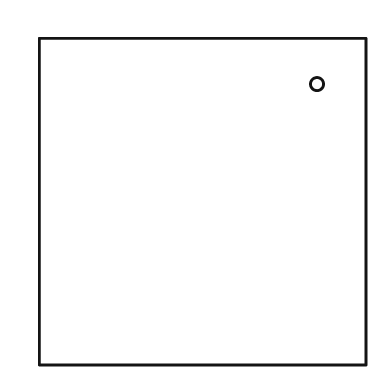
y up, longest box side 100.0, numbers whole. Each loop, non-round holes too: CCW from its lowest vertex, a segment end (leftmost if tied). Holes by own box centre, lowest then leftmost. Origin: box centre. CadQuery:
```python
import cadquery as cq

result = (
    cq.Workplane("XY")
    .moveTo(-50.0, -50.0)
    .lineTo(50.0, -50.0)
    .lineTo(50.0, 50.0)
    .lineTo(-50.0, 50.0)
    .close()
    .moveTo(35.0, 36.0)
    .circle(2.0)
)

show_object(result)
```